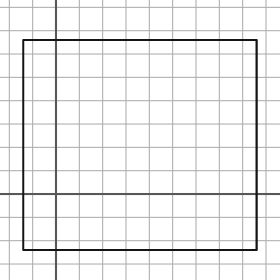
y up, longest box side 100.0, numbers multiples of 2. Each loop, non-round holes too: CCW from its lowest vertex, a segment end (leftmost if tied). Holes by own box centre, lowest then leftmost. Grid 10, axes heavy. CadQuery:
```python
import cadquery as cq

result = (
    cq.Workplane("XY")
    .moveTo(-14.0, -24.0)
    .lineTo(86.0, -24.0)
    .lineTo(86.0, 66.0)
    .lineTo(-14.0, 66.0)
    .close()
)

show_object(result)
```